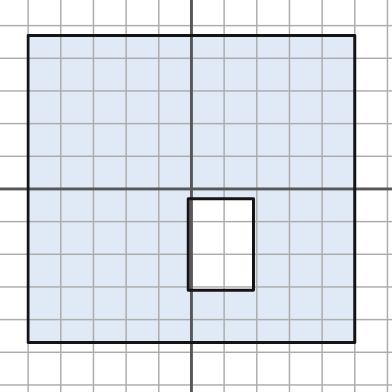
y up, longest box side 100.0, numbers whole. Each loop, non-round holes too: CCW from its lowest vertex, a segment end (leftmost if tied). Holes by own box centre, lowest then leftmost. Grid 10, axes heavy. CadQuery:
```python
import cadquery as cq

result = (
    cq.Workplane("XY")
    .moveTo(-50.0, -47.0)
    .lineTo(50.0, -47.0)
    .lineTo(50.0, 47.0)
    .lineTo(-50.0, 47.0)
    .close()
    .moveTo(-1.0, -31.0)
    .lineTo(19.0, -31.0)
    .lineTo(19.0, -3.0)
    .lineTo(-1.0, -3.0)
    .close()
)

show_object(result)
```